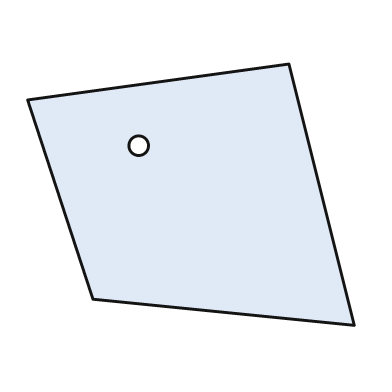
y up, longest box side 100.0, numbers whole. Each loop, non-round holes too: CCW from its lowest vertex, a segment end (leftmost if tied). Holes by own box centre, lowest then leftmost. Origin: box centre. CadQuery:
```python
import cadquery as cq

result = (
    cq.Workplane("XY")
    .moveTo(50.0, -40.0)
    .lineTo(30.0, 40.0)
    .lineTo(-50.0, 29.0)
    .lineTo(-30.0, -32.0)
    .close()
    .moveTo(-16.0, 15.0)
    .circle(3.0)
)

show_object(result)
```